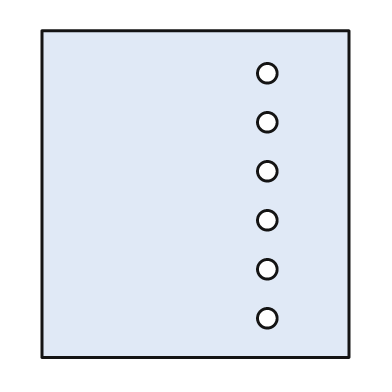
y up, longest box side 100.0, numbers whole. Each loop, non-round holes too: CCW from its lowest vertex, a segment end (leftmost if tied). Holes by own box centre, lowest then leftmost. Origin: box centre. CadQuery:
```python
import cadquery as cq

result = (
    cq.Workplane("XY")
    .moveTo(-47.0, -50.0)
    .lineTo(47.0, -50.0)
    .lineTo(47.0, 50.0)
    .lineTo(-47.0, 50.0)
    .close()
    .moveTo(22.0, -38.0)
    .circle(3.0)
    .moveTo(22.0, -23.0)
    .circle(3.0)
    .moveTo(22.0, -8.0)
    .circle(3.0)
    .moveTo(22.0, 7.0)
    .circle(3.0)
    .moveTo(22.0, 22.0)
    .circle(3.0)
    .moveTo(22.0, 37.0)
    .circle(3.0)
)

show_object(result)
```